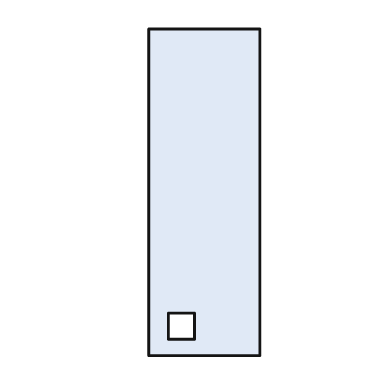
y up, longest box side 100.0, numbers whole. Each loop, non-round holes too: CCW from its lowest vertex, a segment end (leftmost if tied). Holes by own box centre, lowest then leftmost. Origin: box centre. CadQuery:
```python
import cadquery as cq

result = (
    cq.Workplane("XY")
    .moveTo(-17.0, -50.0)
    .lineTo(17.0, -50.0)
    .lineTo(17.0, 50.0)
    .lineTo(-17.0, 50.0)
    .close()
    .moveTo(-11.0, -45.0)
    .lineTo(-3.0, -45.0)
    .lineTo(-3.0, -37.0)
    .lineTo(-11.0, -37.0)
    .close()
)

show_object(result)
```